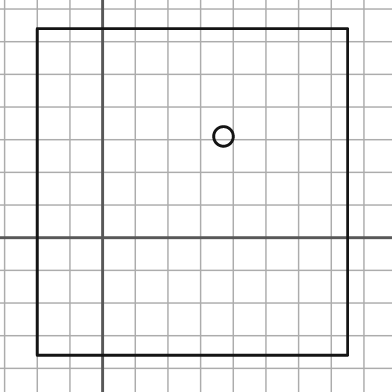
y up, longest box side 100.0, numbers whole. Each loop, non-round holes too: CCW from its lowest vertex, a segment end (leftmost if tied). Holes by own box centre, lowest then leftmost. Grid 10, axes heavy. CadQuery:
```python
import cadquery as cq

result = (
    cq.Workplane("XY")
    .moveTo(-20.0, -36.0)
    .lineTo(75.0, -36.0)
    .lineTo(75.0, 64.0)
    .lineTo(-20.0, 64.0)
    .close()
    .moveTo(37.0, 31.0)
    .circle(3.0)
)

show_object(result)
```